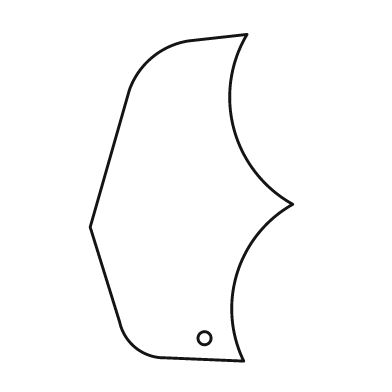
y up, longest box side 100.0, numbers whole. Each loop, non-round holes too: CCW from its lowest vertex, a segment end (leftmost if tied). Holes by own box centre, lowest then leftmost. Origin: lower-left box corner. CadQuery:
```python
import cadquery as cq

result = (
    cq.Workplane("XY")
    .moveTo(47.0, 0.0)
    .threePointArc((45.0, 27.0), (62.0, 48.0))
    .threePointArc((44.0, 71.0), (48.0, 100.0))
    .lineTo(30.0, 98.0)
    .threePointArc((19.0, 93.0), (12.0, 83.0))
    .lineTo(0.0, 41.0)
    .lineTo(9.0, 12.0)
    .threePointArc((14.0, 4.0), (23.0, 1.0))
    .close()
    .moveTo(35.0, 7.0)
    .circle(2.0)
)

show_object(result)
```